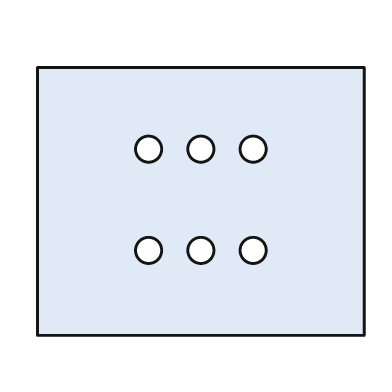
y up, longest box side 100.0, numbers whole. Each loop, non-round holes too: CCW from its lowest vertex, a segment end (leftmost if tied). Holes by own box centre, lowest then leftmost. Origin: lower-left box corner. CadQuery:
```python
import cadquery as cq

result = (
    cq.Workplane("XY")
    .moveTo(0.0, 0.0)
    .lineTo(100.0, 0.0)
    .lineTo(100.0, 82.0)
    .lineTo(0.0, 82.0)
    .close()
    .moveTo(34.0, 26.0)
    .circle(4.0)
    .moveTo(50.0, 26.0)
    .circle(4.0)
    .moveTo(66.0, 26.0)
    .circle(4.0)
    .moveTo(34.0, 57.0)
    .circle(4.0)
    .moveTo(50.0, 57.0)
    .circle(4.0)
    .moveTo(66.0, 57.0)
    .circle(4.0)
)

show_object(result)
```